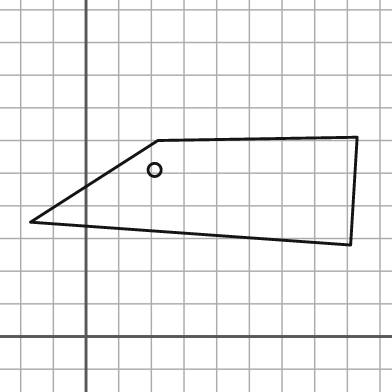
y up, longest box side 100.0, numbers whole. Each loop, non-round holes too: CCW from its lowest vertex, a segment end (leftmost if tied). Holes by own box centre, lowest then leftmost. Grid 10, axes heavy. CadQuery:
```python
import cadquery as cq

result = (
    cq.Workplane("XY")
    .moveTo(81.0, 28.0)
    .lineTo(83.0, 61.0)
    .lineTo(22.0, 60.0)
    .lineTo(-17.0, 35.0)
    .close()
    .moveTo(21.0, 51.0)
    .circle(2.0)
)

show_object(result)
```